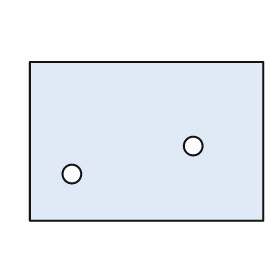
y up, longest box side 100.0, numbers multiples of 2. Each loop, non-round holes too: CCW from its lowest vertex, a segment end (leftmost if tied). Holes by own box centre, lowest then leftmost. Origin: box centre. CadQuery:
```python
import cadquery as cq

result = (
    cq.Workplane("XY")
    .moveTo(-50.0, -34.0)
    .lineTo(50.0, -34.0)
    .lineTo(50.0, 34.0)
    .lineTo(-50.0, 34.0)
    .close()
    .moveTo(-32.0, -14.0)
    .circle(4.0)
    .moveTo(20.0, -2.0)
    .circle(4.0)
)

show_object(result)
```